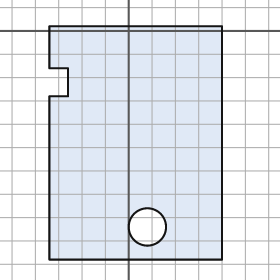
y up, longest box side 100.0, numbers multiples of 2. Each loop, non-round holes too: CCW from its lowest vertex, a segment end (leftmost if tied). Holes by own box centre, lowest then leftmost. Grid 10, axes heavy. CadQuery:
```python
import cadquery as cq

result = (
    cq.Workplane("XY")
    .moveTo(-34.0, -98.0)
    .lineTo(40.0, -98.0)
    .lineTo(40.0, 2.0)
    .lineTo(-34.0, 2.0)
    .lineTo(-34.0, -16.0)
    .lineTo(-26.0, -16.0)
    .lineTo(-26.0, -28.0)
    .lineTo(-34.0, -28.0)
    .close()
    .moveTo(8.0, -84.0)
    .circle(8.0)
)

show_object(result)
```